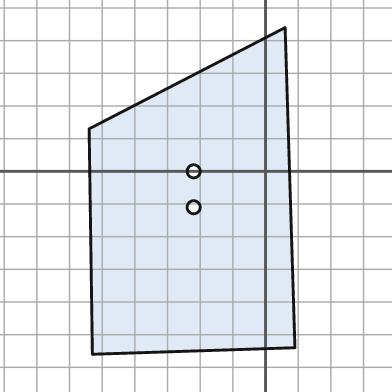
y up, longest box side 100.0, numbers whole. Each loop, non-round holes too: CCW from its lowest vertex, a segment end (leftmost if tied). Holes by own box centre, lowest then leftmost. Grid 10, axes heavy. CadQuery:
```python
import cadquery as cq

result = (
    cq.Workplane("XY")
    .moveTo(-53.0, -56.0)
    .lineTo(9.0, -54.0)
    .lineTo(6.0, 44.0)
    .lineTo(-54.0, 13.0)
    .close()
    .moveTo(-22.0, -11.0)
    .circle(2.0)
    .moveTo(-22.0, 0.0)
    .circle(2.0)
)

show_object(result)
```